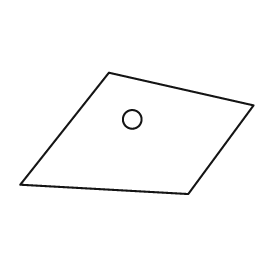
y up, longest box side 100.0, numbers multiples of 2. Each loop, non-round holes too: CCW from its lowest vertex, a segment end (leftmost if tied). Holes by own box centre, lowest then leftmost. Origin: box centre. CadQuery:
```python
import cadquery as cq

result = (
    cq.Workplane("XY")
    .moveTo(22.0, -26.0)
    .lineTo(50.0, 12.0)
    .lineTo(-12.0, 26.0)
    .lineTo(-50.0, -22.0)
    .close()
    .moveTo(-2.0, 6.0)
    .circle(4.0)
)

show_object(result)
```